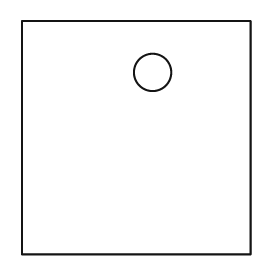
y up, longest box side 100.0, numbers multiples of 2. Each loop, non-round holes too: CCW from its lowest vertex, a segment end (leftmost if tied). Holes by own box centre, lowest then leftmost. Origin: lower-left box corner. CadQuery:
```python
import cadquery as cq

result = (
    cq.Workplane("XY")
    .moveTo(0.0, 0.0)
    .lineTo(98.0, 0.0)
    .lineTo(98.0, 100.0)
    .lineTo(0.0, 100.0)
    .close()
    .moveTo(56.0, 78.0)
    .circle(8.0)
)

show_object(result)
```